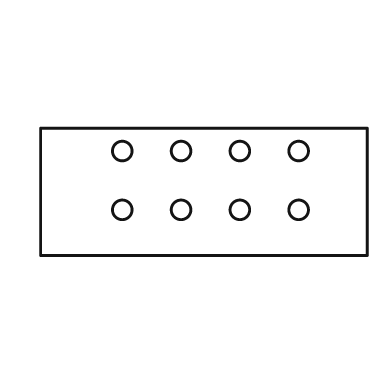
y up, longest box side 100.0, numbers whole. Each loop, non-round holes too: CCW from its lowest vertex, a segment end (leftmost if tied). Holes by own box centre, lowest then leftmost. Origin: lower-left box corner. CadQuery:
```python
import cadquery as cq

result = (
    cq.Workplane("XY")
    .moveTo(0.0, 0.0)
    .lineTo(100.0, 0.0)
    .lineTo(100.0, 39.0)
    .lineTo(0.0, 39.0)
    .close()
    .moveTo(25.0, 14.0)
    .circle(3.0)
    .moveTo(43.0, 14.0)
    .circle(3.0)
    .moveTo(61.0, 14.0)
    .circle(3.0)
    .moveTo(79.0, 14.0)
    .circle(3.0)
    .moveTo(25.0, 32.0)
    .circle(3.0)
    .moveTo(43.0, 32.0)
    .circle(3.0)
    .moveTo(61.0, 32.0)
    .circle(3.0)
    .moveTo(79.0, 32.0)
    .circle(3.0)
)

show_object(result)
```